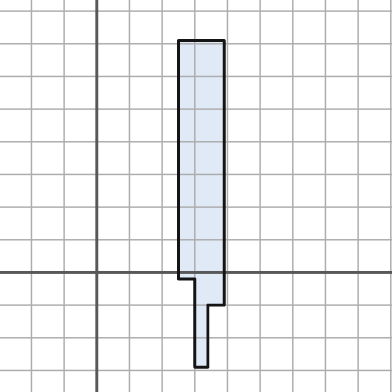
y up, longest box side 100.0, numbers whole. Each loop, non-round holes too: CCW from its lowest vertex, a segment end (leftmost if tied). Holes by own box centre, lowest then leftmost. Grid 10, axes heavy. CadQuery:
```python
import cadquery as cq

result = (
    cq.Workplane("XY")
    .moveTo(30.0, -29.0)
    .lineTo(34.0, -29.0)
    .lineTo(34.0, -10.0)
    .lineTo(39.0, -10.0)
    .lineTo(39.0, 71.0)
    .lineTo(25.0, 71.0)
    .lineTo(25.0, -2.0)
    .lineTo(30.0, -2.0)
    .close()
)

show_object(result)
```